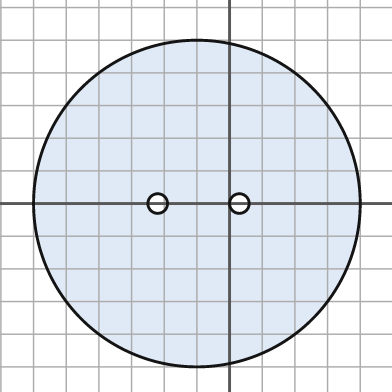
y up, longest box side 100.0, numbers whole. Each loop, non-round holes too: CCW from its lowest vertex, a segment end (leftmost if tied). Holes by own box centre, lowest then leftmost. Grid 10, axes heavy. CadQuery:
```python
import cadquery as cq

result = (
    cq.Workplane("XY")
    .moveTo(-10.0, 0.0)
    .circle(50.0)
    .moveTo(-22.0, 0.0)
    .circle(3.0)
    .moveTo(3.0, 0.0)
    .circle(3.0)
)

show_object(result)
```